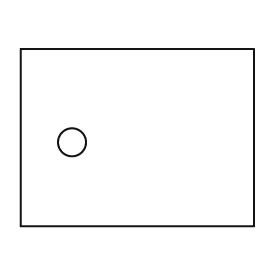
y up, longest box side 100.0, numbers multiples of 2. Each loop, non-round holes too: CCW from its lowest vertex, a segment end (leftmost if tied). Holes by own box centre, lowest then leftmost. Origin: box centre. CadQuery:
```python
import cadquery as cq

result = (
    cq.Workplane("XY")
    .moveTo(-50.0, -38.0)
    .lineTo(50.0, -38.0)
    .lineTo(50.0, 38.0)
    .lineTo(-50.0, 38.0)
    .close()
    .moveTo(-28.0, -2.0)
    .circle(6.0)
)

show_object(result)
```